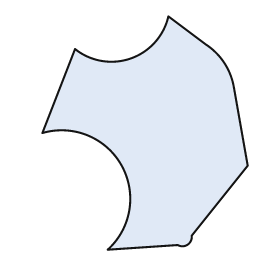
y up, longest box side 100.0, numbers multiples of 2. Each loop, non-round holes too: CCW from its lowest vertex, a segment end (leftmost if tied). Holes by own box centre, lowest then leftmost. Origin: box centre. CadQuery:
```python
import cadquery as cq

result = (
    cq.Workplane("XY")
    .moveTo(-16.0, -50.0)
    .lineTo(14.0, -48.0)
    .threePointArc((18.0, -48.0), (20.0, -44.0))
    .lineTo(44.0, -14.0)
    .lineTo(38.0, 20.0)
    .threePointArc((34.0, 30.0), (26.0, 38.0))
    .lineTo(10.0, 50.0)
    .threePointArc((-6.0, 32.0), (-30.0, 36.0))
    .lineTo(-44.0, 0.0)
    .threePointArc((-10.0, -14.0), (-16.0, -50.0))
    .close()
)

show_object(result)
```